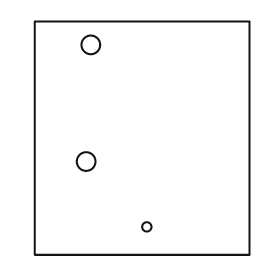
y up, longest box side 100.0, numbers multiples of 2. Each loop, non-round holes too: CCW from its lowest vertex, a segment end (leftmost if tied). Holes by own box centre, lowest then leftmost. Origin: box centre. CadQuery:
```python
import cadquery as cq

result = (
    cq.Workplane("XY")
    .moveTo(-46.0, -50.0)
    .lineTo(46.0, -50.0)
    .lineTo(46.0, 50.0)
    .lineTo(-46.0, 50.0)
    .close()
    .moveTo(2.0, -38.0)
    .circle(2.0)
    .moveTo(-24.0, -10.0)
    .circle(4.0)
    .moveTo(-22.0, 40.0)
    .circle(4.0)
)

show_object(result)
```